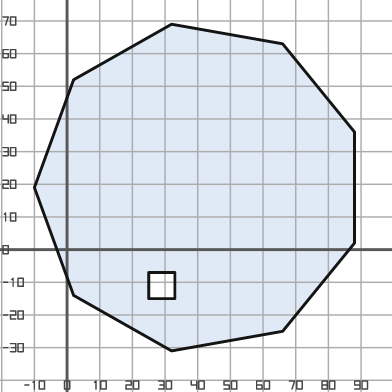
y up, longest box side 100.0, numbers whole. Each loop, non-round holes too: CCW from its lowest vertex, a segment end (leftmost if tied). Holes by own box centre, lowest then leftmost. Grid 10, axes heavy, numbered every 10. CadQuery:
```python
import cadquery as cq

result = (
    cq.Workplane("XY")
    .moveTo(32.0, -31.0)
    .lineTo(66.0, -25.0)
    .lineTo(88.0, 2.0)
    .lineTo(88.0, 36.0)
    .lineTo(66.0, 63.0)
    .lineTo(32.0, 69.0)
    .lineTo(2.0, 52.0)
    .lineTo(-10.0, 19.0)
    .lineTo(2.0, -14.0)
    .close()
    .moveTo(25.0, -15.0)
    .lineTo(33.0, -15.0)
    .lineTo(33.0, -7.0)
    .lineTo(25.0, -7.0)
    .close()
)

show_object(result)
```